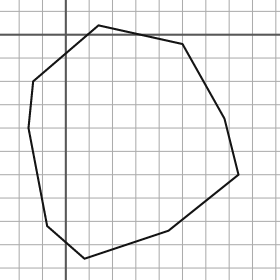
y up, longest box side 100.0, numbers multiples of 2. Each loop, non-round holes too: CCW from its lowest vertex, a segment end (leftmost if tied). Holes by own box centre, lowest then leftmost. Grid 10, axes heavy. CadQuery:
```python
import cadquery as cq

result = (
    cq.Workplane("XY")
    .moveTo(8.0, -96.0)
    .lineTo(44.0, -84.0)
    .lineTo(74.0, -60.0)
    .lineTo(68.0, -36.0)
    .lineTo(50.0, -4.0)
    .lineTo(14.0, 4.0)
    .lineTo(-14.0, -20.0)
    .lineTo(-16.0, -40.0)
    .lineTo(-8.0, -82.0)
    .close()
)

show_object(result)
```